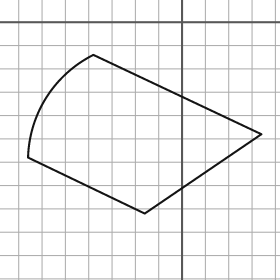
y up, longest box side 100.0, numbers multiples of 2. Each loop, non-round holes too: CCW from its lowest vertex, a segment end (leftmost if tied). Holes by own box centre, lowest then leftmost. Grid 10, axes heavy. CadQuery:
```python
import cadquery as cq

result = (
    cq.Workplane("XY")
    .moveTo(-16.0, -82.0)
    .lineTo(34.0, -48.0)
    .lineTo(-38.0, -14.0)
    .threePointArc((-58.0, -32.0), (-66.0, -58.0))
    .close()
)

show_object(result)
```